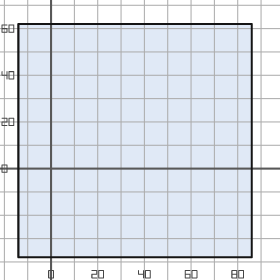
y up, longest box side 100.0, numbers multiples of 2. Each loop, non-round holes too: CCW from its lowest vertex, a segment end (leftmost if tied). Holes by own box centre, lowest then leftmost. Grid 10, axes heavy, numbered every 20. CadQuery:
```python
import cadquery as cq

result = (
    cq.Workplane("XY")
    .moveTo(-14.0, -38.0)
    .lineTo(86.0, -38.0)
    .lineTo(86.0, 62.0)
    .lineTo(-14.0, 62.0)
    .close()
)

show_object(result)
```